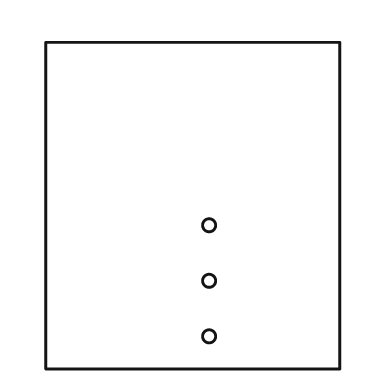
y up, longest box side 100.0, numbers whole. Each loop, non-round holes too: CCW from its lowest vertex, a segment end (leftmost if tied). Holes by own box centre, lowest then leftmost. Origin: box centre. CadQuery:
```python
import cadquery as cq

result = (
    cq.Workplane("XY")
    .moveTo(-45.0, -50.0)
    .lineTo(45.0, -50.0)
    .lineTo(45.0, 50.0)
    .lineTo(-45.0, 50.0)
    .close()
    .moveTo(5.0, -40.0)
    .circle(2.0)
    .moveTo(5.0, -23.0)
    .circle(2.0)
    .moveTo(5.0, -6.0)
    .circle(2.0)
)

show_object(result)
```